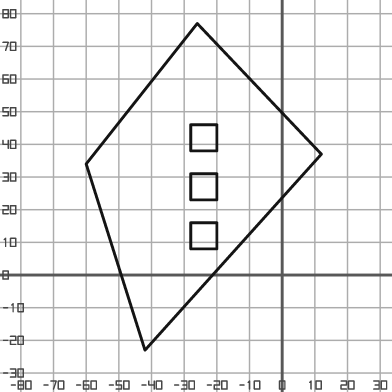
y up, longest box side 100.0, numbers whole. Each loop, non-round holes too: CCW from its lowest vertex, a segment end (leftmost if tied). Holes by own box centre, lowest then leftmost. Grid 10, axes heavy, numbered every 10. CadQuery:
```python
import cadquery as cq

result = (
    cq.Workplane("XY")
    .moveTo(-42.0, -23.0)
    .lineTo(12.0, 37.0)
    .lineTo(-26.0, 77.0)
    .lineTo(-60.0, 34.0)
    .close()
    .moveTo(-28.0, 8.0)
    .lineTo(-20.0, 8.0)
    .lineTo(-20.0, 16.0)
    .lineTo(-28.0, 16.0)
    .close()
    .moveTo(-28.0, 23.0)
    .lineTo(-20.0, 23.0)
    .lineTo(-20.0, 31.0)
    .lineTo(-28.0, 31.0)
    .close()
    .moveTo(-28.0, 38.0)
    .lineTo(-20.0, 38.0)
    .lineTo(-20.0, 46.0)
    .lineTo(-28.0, 46.0)
    .close()
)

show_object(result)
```